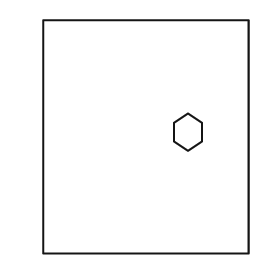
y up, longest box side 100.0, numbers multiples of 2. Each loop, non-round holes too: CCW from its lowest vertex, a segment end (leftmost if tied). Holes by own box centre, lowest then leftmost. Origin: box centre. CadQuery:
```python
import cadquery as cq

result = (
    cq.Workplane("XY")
    .moveTo(-44.0, -50.0)
    .lineTo(44.0, -50.0)
    .lineTo(44.0, 50.0)
    .lineTo(-44.0, 50.0)
    .close()
    .moveTo(18.0, -6.0)
    .lineTo(24.0, -2.0)
    .lineTo(24.0, 6.0)
    .lineTo(18.0, 10.0)
    .lineTo(12.0, 6.0)
    .lineTo(12.0, -2.0)
    .close()
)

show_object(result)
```